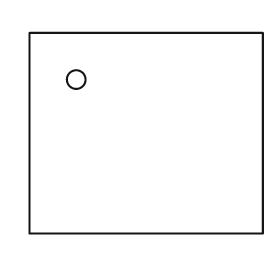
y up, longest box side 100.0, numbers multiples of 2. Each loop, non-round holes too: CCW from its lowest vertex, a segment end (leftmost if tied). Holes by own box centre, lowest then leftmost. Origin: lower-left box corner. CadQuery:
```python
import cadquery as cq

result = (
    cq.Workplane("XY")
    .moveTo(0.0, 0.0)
    .lineTo(100.0, 0.0)
    .lineTo(100.0, 86.0)
    .lineTo(0.0, 86.0)
    .close()
    .moveTo(20.0, 66.0)
    .circle(4.0)
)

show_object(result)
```